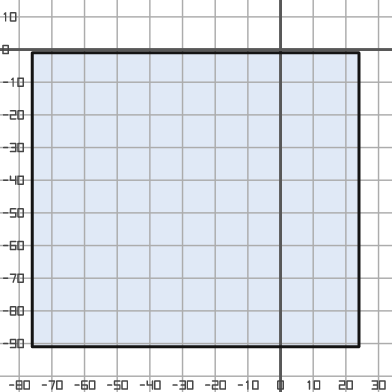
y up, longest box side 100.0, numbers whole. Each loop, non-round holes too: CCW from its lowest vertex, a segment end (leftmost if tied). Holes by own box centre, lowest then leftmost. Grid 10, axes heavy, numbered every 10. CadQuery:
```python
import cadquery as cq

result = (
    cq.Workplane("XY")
    .moveTo(-76.0, -91.0)
    .lineTo(24.0, -91.0)
    .lineTo(24.0, -1.0)
    .lineTo(-76.0, -1.0)
    .close()
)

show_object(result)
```